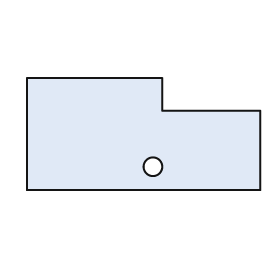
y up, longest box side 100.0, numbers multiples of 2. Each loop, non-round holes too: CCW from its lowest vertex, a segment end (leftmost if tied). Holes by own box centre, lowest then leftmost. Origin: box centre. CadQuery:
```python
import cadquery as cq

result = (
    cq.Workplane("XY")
    .moveTo(-50.0, -24.0)
    .lineTo(50.0, -24.0)
    .lineTo(50.0, 10.0)
    .lineTo(8.0, 10.0)
    .lineTo(8.0, 24.0)
    .lineTo(-50.0, 24.0)
    .close()
    .moveTo(4.0, -14.0)
    .circle(4.0)
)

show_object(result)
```